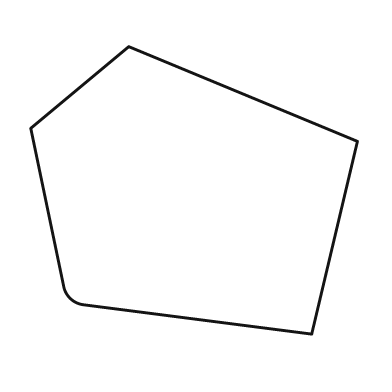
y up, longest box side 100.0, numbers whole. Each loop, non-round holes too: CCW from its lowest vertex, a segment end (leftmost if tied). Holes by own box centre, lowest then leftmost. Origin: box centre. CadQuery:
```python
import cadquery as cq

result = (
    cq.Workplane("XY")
    .moveTo(36.0, -44.0)
    .lineTo(50.0, 15.0)
    .lineTo(-20.0, 44.0)
    .lineTo(-50.0, 19.0)
    .lineTo(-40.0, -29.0)
    .threePointArc((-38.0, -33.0), (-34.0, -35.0))
    .close()
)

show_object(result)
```